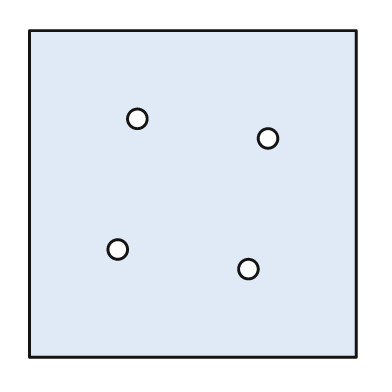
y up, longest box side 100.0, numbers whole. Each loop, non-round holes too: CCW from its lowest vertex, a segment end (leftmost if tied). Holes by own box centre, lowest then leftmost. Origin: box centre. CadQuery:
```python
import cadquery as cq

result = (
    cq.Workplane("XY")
    .moveTo(-50.0, -50.0)
    .lineTo(50.0, -50.0)
    .lineTo(50.0, 50.0)
    .lineTo(-50.0, 50.0)
    .close()
    .moveTo(17.0, -23.0)
    .circle(3.0)
    .moveTo(-23.0, -17.0)
    .circle(3.0)
    .moveTo(23.0, 17.0)
    .circle(3.0)
    .moveTo(-17.0, 23.0)
    .circle(3.0)
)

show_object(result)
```